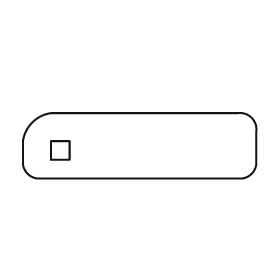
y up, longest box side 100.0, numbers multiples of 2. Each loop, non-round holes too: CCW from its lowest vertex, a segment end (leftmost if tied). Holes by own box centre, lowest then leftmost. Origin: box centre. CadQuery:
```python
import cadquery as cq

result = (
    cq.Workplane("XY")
    .moveTo(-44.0, -14.0)
    .lineTo(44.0, -14.0)
    .threePointArc((48.0, -12.0), (50.0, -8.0))
    .lineTo(50.0, 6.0)
    .threePointArc((48.0, 12.0), (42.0, 14.0))
    .lineTo(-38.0, 14.0)
    .threePointArc((-46.0, 10.0), (-50.0, 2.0))
    .lineTo(-50.0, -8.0)
    .threePointArc((-48.0, -12.0), (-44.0, -14.0))
    .close()
    .moveTo(-38.0, -6.0)
    .lineTo(-30.0, -6.0)
    .lineTo(-30.0, 2.0)
    .lineTo(-38.0, 2.0)
    .close()
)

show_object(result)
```